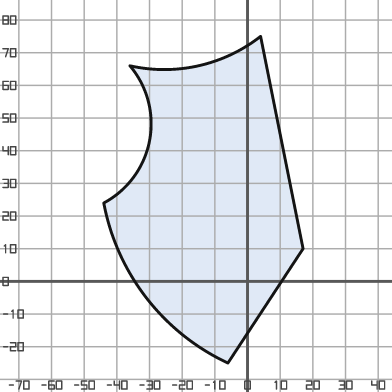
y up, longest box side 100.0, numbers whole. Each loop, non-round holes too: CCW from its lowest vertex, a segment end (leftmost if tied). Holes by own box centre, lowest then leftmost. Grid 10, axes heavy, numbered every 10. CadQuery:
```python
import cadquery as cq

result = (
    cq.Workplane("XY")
    .moveTo(-6.0, -25.0)
    .lineTo(17.0, 10.0)
    .lineTo(4.0, 75.0)
    .threePointArc((-15.0, 66.0), (-36.0, 66.0))
    .threePointArc((-30.0, 43.0), (-44.0, 24.0))
    .threePointArc((-31.0, -5.0), (-6.0, -25.0))
    .close()
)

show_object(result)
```